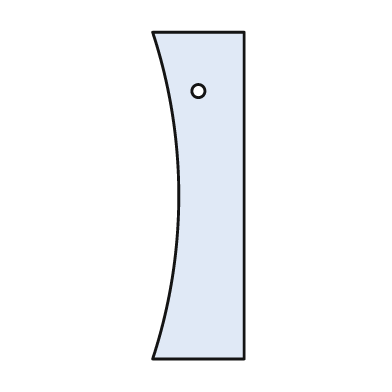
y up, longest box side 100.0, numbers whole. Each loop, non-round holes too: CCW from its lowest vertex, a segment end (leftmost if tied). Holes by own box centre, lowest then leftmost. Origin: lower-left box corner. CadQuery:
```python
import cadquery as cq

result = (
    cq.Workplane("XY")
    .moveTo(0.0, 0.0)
    .lineTo(28.0, 0.0)
    .lineTo(28.0, 100.0)
    .lineTo(0.0, 100.0)
    .threePointArc((8.0, 50.0), (0.0, 0.0))
    .close()
    .moveTo(14.0, 82.0)
    .circle(2.0)
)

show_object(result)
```